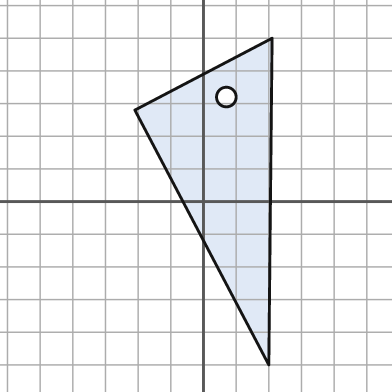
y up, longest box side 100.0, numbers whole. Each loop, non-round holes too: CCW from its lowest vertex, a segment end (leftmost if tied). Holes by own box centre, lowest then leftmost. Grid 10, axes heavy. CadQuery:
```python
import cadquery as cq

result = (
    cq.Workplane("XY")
    .moveTo(20.0, -50.0)
    .lineTo(21.0, 50.0)
    .lineTo(-21.0, 28.0)
    .close()
    .moveTo(7.0, 32.0)
    .circle(3.0)
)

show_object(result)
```